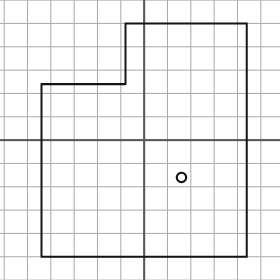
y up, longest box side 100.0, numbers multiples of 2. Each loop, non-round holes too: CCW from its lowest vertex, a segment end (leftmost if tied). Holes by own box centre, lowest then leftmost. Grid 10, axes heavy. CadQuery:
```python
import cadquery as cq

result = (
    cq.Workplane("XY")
    .moveTo(-44.0, -50.0)
    .lineTo(44.0, -50.0)
    .lineTo(44.0, 50.0)
    .lineTo(-8.0, 50.0)
    .lineTo(-8.0, 24.0)
    .lineTo(-44.0, 24.0)
    .close()
    .moveTo(16.0, -16.0)
    .circle(2.0)
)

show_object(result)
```